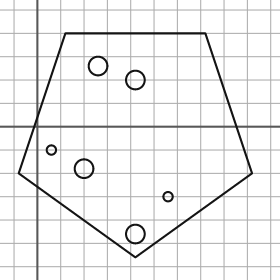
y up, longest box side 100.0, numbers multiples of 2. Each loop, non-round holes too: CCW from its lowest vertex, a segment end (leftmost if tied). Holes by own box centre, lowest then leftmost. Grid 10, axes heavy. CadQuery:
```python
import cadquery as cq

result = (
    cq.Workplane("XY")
    .moveTo(42.0, -56.0)
    .lineTo(92.0, -20.0)
    .lineTo(72.0, 40.0)
    .lineTo(12.0, 40.0)
    .lineTo(-8.0, -20.0)
    .close()
    .moveTo(42.0, -46.0)
    .circle(4.0)
    .moveTo(56.0, -30.0)
    .circle(2.0)
    .moveTo(20.0, -18.0)
    .circle(4.0)
    .moveTo(6.0, -10.0)
    .circle(2.0)
    .moveTo(42.0, 20.0)
    .circle(4.0)
    .moveTo(26.0, 26.0)
    .circle(4.0)
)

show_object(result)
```